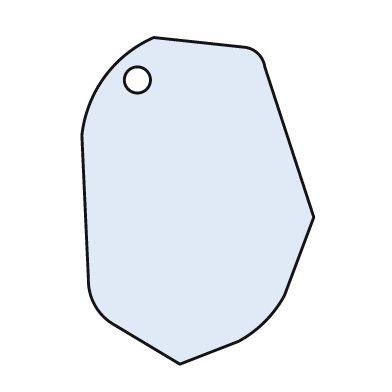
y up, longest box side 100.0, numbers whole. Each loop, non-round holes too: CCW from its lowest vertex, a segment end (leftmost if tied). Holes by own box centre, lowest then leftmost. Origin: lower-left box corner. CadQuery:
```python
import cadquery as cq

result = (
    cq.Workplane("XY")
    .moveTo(30.0, 0.0)
    .lineTo(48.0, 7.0)
    .threePointArc((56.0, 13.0), (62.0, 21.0))
    .lineTo(71.0, 45.0)
    .lineTo(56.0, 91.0)
    .threePointArc((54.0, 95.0), (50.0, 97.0))
    .lineTo(22.0, 100.0)
    .threePointArc((7.0, 88.0), (0.0, 70.0))
    .lineTo(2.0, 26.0)
    .threePointArc((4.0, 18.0), (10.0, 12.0))
    .close()
    .moveTo(17.0, 87.0)
    .circle(4.0)
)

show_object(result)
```